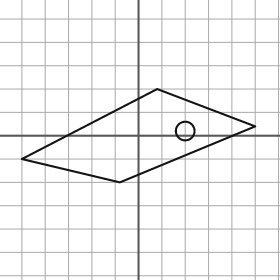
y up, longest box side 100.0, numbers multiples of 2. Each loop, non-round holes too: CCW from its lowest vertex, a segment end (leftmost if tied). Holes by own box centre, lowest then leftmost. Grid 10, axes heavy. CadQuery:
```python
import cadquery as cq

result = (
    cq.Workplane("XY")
    .moveTo(-8.0, -20.0)
    .lineTo(50.0, 4.0)
    .lineTo(8.0, 20.0)
    .lineTo(-50.0, -10.0)
    .close()
    .moveTo(20.0, 2.0)
    .circle(4.0)
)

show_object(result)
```